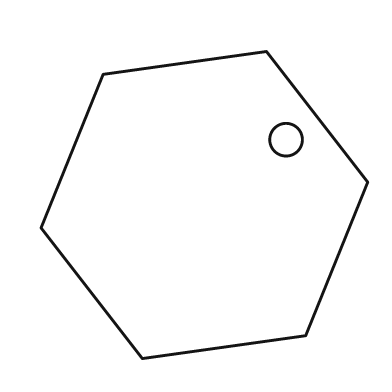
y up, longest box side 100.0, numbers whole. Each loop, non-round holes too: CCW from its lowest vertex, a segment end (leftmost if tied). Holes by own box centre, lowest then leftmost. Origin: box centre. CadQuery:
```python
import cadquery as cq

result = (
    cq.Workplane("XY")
    .moveTo(-19.0, -47.0)
    .lineTo(31.0, -40.0)
    .lineTo(50.0, 7.0)
    .lineTo(19.0, 47.0)
    .lineTo(-31.0, 40.0)
    .lineTo(-50.0, -7.0)
    .close()
    .moveTo(25.0, 20.0)
    .circle(5.0)
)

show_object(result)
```